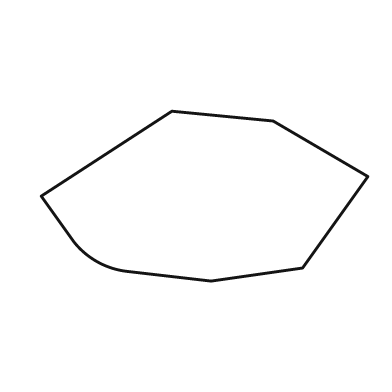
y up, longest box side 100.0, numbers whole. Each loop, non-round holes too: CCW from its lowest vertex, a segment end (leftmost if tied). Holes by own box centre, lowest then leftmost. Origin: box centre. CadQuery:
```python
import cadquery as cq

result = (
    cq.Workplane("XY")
    .moveTo(2.0, -26.0)
    .lineTo(30.0, -22.0)
    .lineTo(50.0, 6.0)
    .lineTo(21.0, 23.0)
    .lineTo(-10.0, 26.0)
    .lineTo(-50.0, 0.0)
    .lineTo(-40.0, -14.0)
    .threePointArc((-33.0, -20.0), (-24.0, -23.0))
    .close()
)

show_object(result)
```